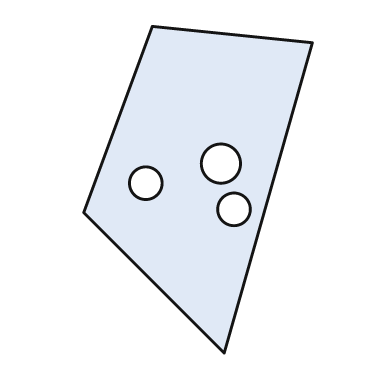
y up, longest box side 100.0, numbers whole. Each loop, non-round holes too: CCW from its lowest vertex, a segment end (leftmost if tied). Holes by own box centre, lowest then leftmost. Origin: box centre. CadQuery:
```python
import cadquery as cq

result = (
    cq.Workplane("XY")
    .moveTo(8.0, -50.0)
    .lineTo(35.0, 45.0)
    .lineTo(-14.0, 50.0)
    .lineTo(-35.0, -7.0)
    .close()
    .moveTo(11.0, -6.0)
    .circle(5.0)
    .moveTo(-16.0, 2.0)
    .circle(5.0)
    .moveTo(7.0, 8.0)
    .circle(6.0)
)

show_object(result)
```